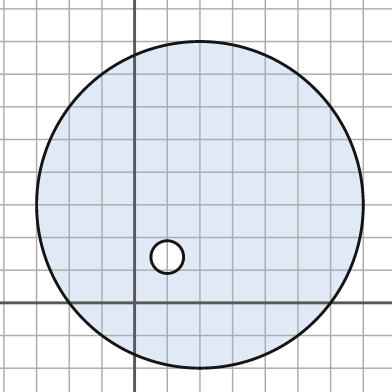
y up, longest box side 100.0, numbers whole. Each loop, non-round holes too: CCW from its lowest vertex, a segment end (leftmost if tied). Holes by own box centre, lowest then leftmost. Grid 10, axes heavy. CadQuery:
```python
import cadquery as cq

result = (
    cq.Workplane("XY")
    .moveTo(20.0, 30.0)
    .circle(50.0)
    .moveTo(10.0, 14.0)
    .circle(5.0)
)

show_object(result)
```